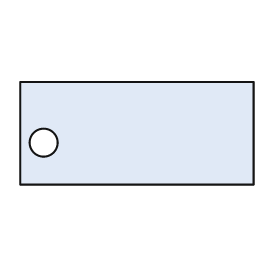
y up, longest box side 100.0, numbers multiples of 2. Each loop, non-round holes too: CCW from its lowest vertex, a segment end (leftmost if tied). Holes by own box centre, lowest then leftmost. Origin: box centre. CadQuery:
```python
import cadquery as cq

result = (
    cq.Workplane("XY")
    .moveTo(-50.0, -22.0)
    .lineTo(50.0, -22.0)
    .lineTo(50.0, 22.0)
    .lineTo(-50.0, 22.0)
    .close()
    .moveTo(-40.0, -4.0)
    .circle(6.0)
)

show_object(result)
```